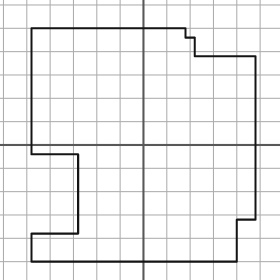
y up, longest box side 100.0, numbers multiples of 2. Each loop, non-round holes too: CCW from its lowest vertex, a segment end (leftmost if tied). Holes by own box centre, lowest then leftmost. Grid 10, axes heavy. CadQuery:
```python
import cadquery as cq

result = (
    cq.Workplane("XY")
    .moveTo(-48.0, -50.0)
    .lineTo(40.0, -50.0)
    .lineTo(40.0, -32.0)
    .lineTo(48.0, -32.0)
    .lineTo(48.0, 38.0)
    .lineTo(22.0, 38.0)
    .lineTo(22.0, 46.0)
    .lineTo(18.0, 46.0)
    .lineTo(18.0, 50.0)
    .lineTo(-48.0, 50.0)
    .lineTo(-48.0, -4.0)
    .lineTo(-28.0, -4.0)
    .lineTo(-28.0, -38.0)
    .lineTo(-48.0, -38.0)
    .close()
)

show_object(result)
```